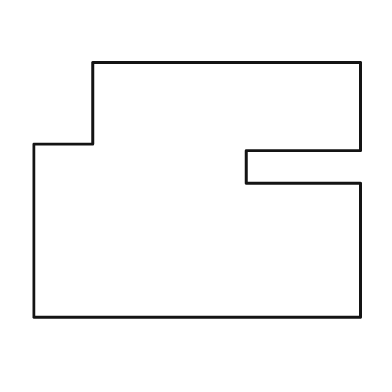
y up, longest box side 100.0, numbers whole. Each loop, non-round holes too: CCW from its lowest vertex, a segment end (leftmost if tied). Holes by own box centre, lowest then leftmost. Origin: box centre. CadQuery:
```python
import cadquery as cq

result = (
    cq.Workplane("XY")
    .moveTo(-50.0, -39.0)
    .lineTo(50.0, -39.0)
    .lineTo(50.0, 2.0)
    .lineTo(15.0, 2.0)
    .lineTo(15.0, 12.0)
    .lineTo(50.0, 12.0)
    .lineTo(50.0, 39.0)
    .lineTo(-32.0, 39.0)
    .lineTo(-32.0, 14.0)
    .lineTo(-50.0, 14.0)
    .close()
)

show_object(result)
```